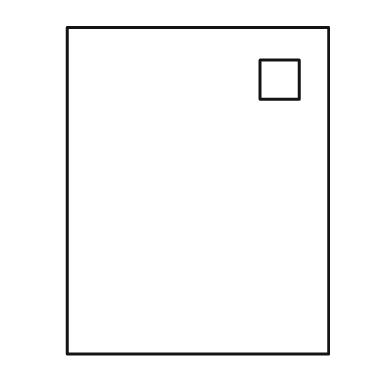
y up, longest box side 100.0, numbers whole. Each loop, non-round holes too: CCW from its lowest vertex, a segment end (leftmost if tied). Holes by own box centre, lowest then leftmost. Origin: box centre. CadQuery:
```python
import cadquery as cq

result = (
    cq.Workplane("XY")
    .moveTo(-40.0, -50.0)
    .lineTo(40.0, -50.0)
    .lineTo(40.0, 50.0)
    .lineTo(-40.0, 50.0)
    .close()
    .moveTo(19.0, 28.0)
    .lineTo(31.0, 28.0)
    .lineTo(31.0, 40.0)
    .lineTo(19.0, 40.0)
    .close()
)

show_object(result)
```